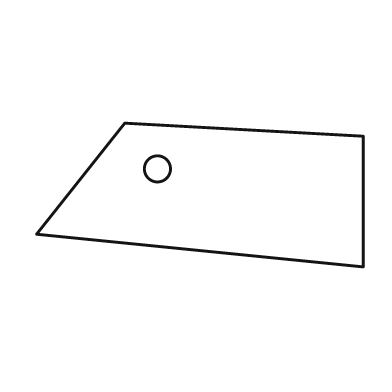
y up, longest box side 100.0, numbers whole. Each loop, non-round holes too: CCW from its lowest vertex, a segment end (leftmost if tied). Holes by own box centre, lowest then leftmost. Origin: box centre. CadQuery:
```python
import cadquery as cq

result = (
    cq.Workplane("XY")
    .moveTo(50.0, -22.0)
    .lineTo(50.0, 18.0)
    .lineTo(-23.0, 22.0)
    .lineTo(-50.0, -12.0)
    .close()
    .moveTo(-13.0, 8.0)
    .circle(4.0)
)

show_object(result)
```